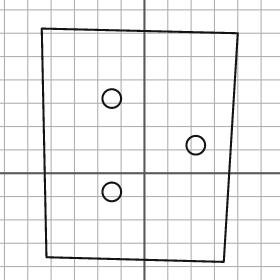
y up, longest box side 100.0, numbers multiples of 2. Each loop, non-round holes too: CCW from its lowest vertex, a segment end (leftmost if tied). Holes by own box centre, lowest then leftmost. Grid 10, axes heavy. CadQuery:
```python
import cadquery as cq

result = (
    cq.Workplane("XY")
    .moveTo(34.0, -38.0)
    .lineTo(40.0, 60.0)
    .lineTo(-44.0, 62.0)
    .lineTo(-42.0, -36.0)
    .close()
    .moveTo(-14.0, -8.0)
    .circle(4.0)
    .moveTo(22.0, 12.0)
    .circle(4.0)
    .moveTo(-14.0, 32.0)
    .circle(4.0)
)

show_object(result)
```